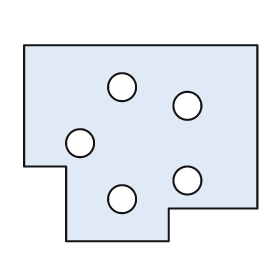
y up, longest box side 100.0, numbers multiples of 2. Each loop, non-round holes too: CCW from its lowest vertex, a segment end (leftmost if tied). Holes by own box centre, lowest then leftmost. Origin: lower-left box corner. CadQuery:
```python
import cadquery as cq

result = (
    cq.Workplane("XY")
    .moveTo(18.0, 0.0)
    .lineTo(62.0, 0.0)
    .lineTo(62.0, 14.0)
    .lineTo(100.0, 14.0)
    .lineTo(100.0, 84.0)
    .lineTo(0.0, 84.0)
    .lineTo(0.0, 32.0)
    .lineTo(18.0, 32.0)
    .close()
    .moveTo(42.0, 18.0)
    .circle(6.0)
    .moveTo(70.0, 26.0)
    .circle(6.0)
    .moveTo(24.0, 42.0)
    .circle(6.0)
    .moveTo(70.0, 58.0)
    .circle(6.0)
    .moveTo(42.0, 66.0)
    .circle(6.0)
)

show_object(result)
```